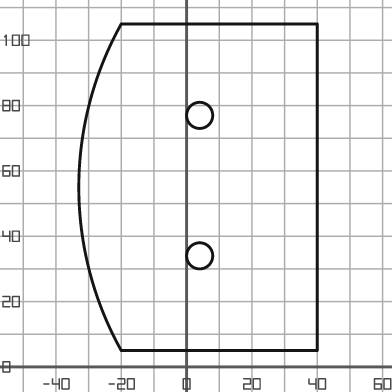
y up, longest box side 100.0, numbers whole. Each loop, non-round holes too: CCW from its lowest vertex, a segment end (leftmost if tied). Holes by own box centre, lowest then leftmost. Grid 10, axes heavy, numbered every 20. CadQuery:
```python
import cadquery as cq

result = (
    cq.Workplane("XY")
    .moveTo(-20.0, 5.0)
    .lineTo(40.0, 5.0)
    .lineTo(40.0, 105.0)
    .lineTo(-20.0, 105.0)
    .threePointArc((-33.0, 55.0), (-20.0, 5.0))
    .close()
    .moveTo(4.0, 34.0)
    .circle(4.0)
    .moveTo(4.0, 77.0)
    .circle(4.0)
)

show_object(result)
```